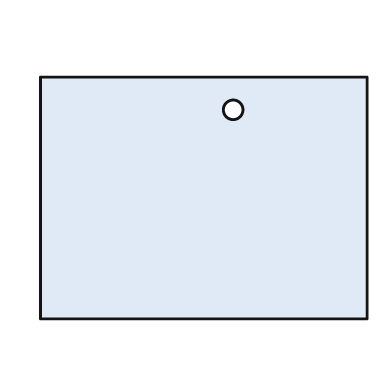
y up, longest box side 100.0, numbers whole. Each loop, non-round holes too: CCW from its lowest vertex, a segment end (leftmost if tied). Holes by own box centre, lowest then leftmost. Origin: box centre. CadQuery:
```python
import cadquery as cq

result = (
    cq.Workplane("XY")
    .moveTo(-50.0, -37.0)
    .lineTo(50.0, -37.0)
    .lineTo(50.0, 37.0)
    .lineTo(-50.0, 37.0)
    .close()
    .moveTo(9.0, 27.0)
    .circle(3.0)
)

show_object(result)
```